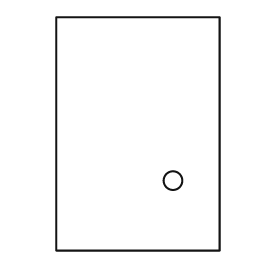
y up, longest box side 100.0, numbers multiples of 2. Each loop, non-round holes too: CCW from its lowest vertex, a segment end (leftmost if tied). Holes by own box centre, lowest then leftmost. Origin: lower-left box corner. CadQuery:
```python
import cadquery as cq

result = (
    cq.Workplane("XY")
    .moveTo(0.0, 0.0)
    .lineTo(70.0, 0.0)
    .lineTo(70.0, 100.0)
    .lineTo(0.0, 100.0)
    .close()
    .moveTo(50.0, 30.0)
    .circle(4.0)
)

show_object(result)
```